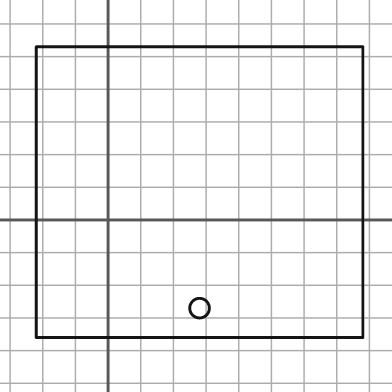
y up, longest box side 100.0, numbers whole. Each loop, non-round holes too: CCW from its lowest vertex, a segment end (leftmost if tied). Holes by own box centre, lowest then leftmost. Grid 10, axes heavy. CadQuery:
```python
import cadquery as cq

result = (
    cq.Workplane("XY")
    .moveTo(-22.0, -36.0)
    .lineTo(78.0, -36.0)
    .lineTo(78.0, 53.0)
    .lineTo(-22.0, 53.0)
    .close()
    .moveTo(28.0, -27.0)
    .circle(3.0)
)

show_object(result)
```